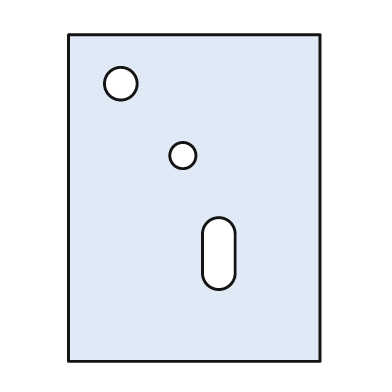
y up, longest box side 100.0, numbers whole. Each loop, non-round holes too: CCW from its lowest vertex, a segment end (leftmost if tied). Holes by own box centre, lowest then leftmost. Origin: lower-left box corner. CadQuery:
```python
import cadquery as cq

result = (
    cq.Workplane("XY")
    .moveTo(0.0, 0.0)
    .lineTo(77.0, 0.0)
    .lineTo(77.0, 100.0)
    .lineTo(0.0, 100.0)
    .close()
    .moveTo(41.0, 27.0)
    .threePointArc((46.0, 22.0), (51.0, 27.0))
    .lineTo(51.0, 39.0)
    .threePointArc((46.0, 44.0), (41.0, 39.0))
    .close()
    .moveTo(35.0, 63.0)
    .circle(4.0)
    .moveTo(16.0, 85.0)
    .circle(5.0)
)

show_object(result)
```